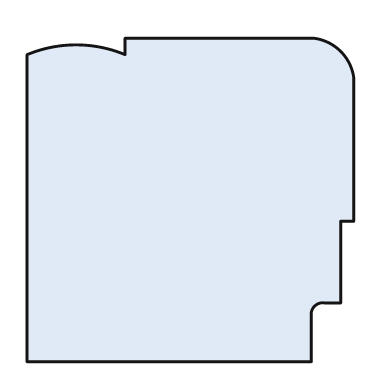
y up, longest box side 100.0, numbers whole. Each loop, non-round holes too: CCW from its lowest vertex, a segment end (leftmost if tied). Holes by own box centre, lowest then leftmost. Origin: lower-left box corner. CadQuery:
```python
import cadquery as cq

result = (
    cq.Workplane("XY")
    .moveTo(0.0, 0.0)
    .lineTo(87.0, 0.0)
    .lineTo(87.0, 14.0)
    .threePointArc((88.0, 17.0), (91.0, 18.0))
    .lineTo(96.0, 18.0)
    .lineTo(96.0, 43.0)
    .lineTo(100.0, 43.0)
    .lineTo(100.0, 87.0)
    .threePointArc((96.0, 95.0), (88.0, 99.0))
    .lineTo(30.0, 99.0)
    .lineTo(30.0, 94.0)
    .threePointArc((15.0, 97.0), (0.0, 94.0))
    .close()
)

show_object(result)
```